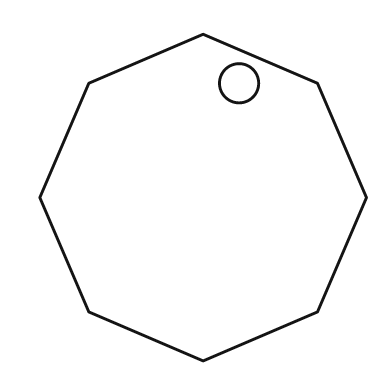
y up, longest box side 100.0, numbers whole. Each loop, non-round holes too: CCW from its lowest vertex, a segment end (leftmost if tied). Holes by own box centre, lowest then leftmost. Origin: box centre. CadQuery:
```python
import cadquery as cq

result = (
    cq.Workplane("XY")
    .moveTo(0.0, -50.0)
    .lineTo(35.0, -35.0)
    .lineTo(50.0, 0.0)
    .lineTo(35.0, 35.0)
    .lineTo(0.0, 50.0)
    .lineTo(-35.0, 35.0)
    .lineTo(-50.0, 0.0)
    .lineTo(-35.0, -35.0)
    .close()
    .moveTo(11.0, 35.0)
    .circle(6.0)
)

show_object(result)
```